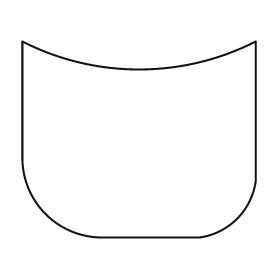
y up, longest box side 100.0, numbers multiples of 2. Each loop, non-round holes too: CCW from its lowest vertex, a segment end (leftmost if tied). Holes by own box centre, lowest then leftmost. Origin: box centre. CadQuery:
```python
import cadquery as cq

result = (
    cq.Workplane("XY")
    .moveTo(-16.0, -42.0)
    .lineTo(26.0, -42.0)
    .threePointArc((42.0, -34.0), (50.0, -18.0))
    .lineTo(50.0, 42.0)
    .threePointArc((0.0, 30.0), (-50.0, 42.0))
    .lineTo(-50.0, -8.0)
    .threePointArc((-40.0, -32.0), (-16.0, -42.0))
    .close()
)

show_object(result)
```